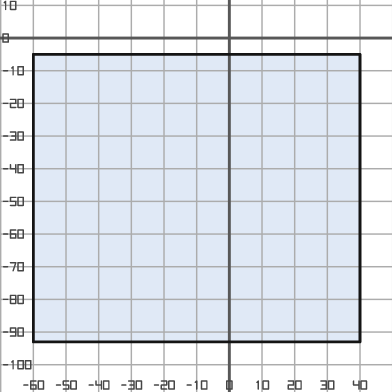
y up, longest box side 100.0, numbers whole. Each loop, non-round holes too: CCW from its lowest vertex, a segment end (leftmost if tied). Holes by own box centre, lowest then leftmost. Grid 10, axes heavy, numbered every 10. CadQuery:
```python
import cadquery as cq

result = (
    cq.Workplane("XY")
    .moveTo(-60.0, -93.0)
    .lineTo(40.0, -93.0)
    .lineTo(40.0, -5.0)
    .lineTo(-60.0, -5.0)
    .close()
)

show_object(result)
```